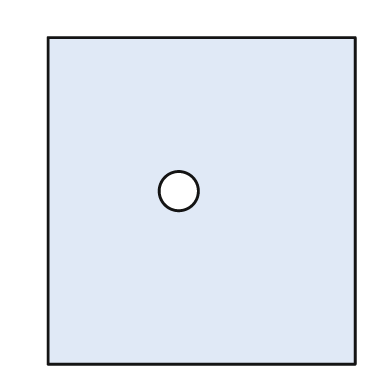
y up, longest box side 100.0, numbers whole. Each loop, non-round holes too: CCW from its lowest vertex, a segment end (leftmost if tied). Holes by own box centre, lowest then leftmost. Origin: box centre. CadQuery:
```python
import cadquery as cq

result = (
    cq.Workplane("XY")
    .moveTo(-47.0, -50.0)
    .lineTo(47.0, -50.0)
    .lineTo(47.0, 50.0)
    .lineTo(-47.0, 50.0)
    .close()
    .moveTo(-7.0, 3.0)
    .circle(6.0)
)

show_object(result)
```